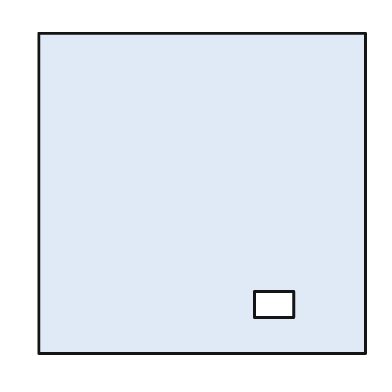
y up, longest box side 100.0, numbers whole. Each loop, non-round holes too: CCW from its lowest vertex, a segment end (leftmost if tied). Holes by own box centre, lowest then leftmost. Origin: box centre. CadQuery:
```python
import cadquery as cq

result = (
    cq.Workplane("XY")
    .moveTo(-50.0, -49.0)
    .lineTo(50.0, -49.0)
    .lineTo(50.0, 49.0)
    .lineTo(-50.0, 49.0)
    .close()
    .moveTo(16.0, -38.0)
    .lineTo(28.0, -38.0)
    .lineTo(28.0, -30.0)
    .lineTo(16.0, -30.0)
    .close()
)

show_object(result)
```